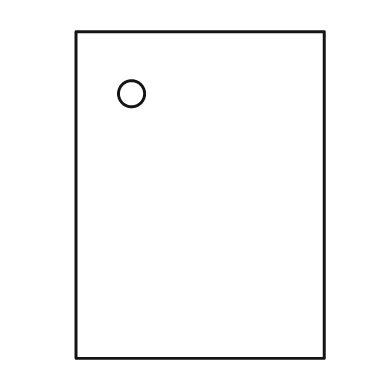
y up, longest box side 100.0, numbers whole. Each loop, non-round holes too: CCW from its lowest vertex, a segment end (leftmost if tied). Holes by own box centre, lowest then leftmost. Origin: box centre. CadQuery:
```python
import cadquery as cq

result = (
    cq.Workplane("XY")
    .moveTo(-38.0, -50.0)
    .lineTo(38.0, -50.0)
    .lineTo(38.0, 50.0)
    .lineTo(-38.0, 50.0)
    .close()
    .moveTo(-21.0, 31.0)
    .circle(4.0)
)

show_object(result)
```